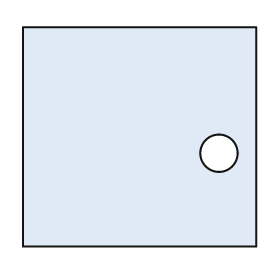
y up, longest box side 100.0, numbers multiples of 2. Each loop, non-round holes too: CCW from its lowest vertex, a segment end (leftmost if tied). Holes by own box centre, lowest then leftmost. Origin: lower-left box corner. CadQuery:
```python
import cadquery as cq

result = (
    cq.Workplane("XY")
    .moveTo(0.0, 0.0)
    .lineTo(100.0, 0.0)
    .lineTo(100.0, 94.0)
    .lineTo(0.0, 94.0)
    .close()
    .moveTo(84.0, 40.0)
    .circle(8.0)
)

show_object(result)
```